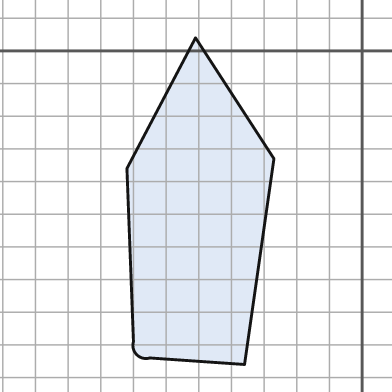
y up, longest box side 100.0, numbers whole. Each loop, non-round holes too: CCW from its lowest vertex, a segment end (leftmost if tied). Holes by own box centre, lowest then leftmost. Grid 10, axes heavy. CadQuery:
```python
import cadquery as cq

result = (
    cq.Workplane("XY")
    .moveTo(-36.0, -96.0)
    .lineTo(-27.0, -33.0)
    .lineTo(-51.0, 4.0)
    .lineTo(-72.0, -36.0)
    .lineTo(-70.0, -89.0)
    .threePointArc((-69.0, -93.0), (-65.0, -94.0))
    .close()
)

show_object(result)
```